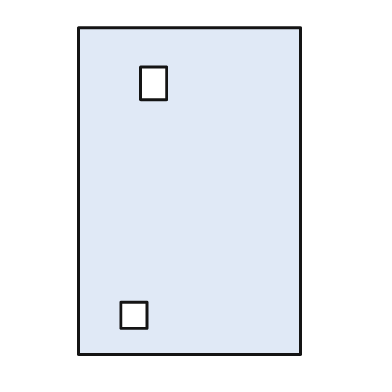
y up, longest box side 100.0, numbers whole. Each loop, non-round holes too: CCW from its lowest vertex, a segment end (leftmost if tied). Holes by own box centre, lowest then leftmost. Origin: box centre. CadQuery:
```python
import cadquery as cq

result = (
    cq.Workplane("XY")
    .moveTo(-34.0, -50.0)
    .lineTo(34.0, -50.0)
    .lineTo(34.0, 50.0)
    .lineTo(-34.0, 50.0)
    .close()
    .moveTo(-21.0, -42.0)
    .lineTo(-13.0, -42.0)
    .lineTo(-13.0, -34.0)
    .lineTo(-21.0, -34.0)
    .close()
    .moveTo(-15.0, 28.0)
    .lineTo(-7.0, 28.0)
    .lineTo(-7.0, 38.0)
    .lineTo(-15.0, 38.0)
    .close()
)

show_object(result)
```